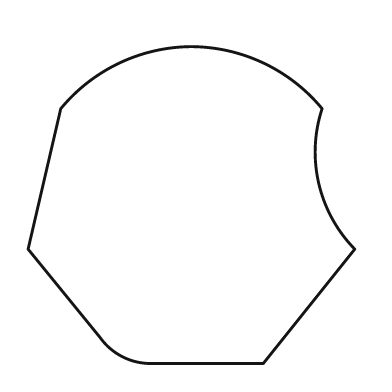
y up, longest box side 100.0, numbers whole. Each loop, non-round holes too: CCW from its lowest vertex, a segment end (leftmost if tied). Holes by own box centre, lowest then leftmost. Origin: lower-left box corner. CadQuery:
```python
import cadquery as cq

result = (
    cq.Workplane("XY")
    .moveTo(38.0, 0.0)
    .lineTo(72.0, 0.0)
    .lineTo(100.0, 35.0)
    .threePointArc((89.0, 55.0), (90.0, 78.0))
    .threePointArc((72.0, 92.0), (50.0, 97.0))
    .threePointArc((28.0, 92.0), (10.0, 78.0))
    .lineTo(0.0, 35.0)
    .lineTo(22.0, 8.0)
    .threePointArc((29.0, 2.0), (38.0, 0.0))
    .close()
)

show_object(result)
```